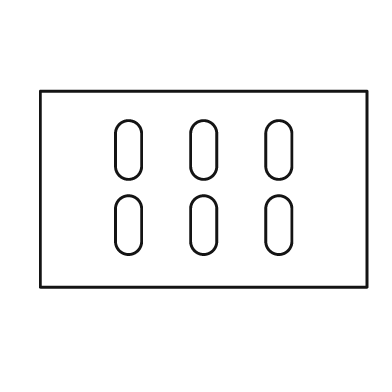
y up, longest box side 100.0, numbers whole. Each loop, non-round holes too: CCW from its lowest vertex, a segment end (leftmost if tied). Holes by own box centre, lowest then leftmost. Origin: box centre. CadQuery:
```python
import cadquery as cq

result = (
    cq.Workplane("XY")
    .moveTo(-50.0, -30.0)
    .lineTo(50.0, -30.0)
    .lineTo(50.0, 30.0)
    .lineTo(-50.0, 30.0)
    .close()
    .moveTo(-27.0, -16.0)
    .threePointArc((-23.0, -20.0), (-19.0, -16.0))
    .lineTo(-19.0, -6.0)
    .threePointArc((-23.0, -2.0), (-27.0, -6.0))
    .close()
    .moveTo(-4.0, -16.0)
    .threePointArc((0.0, -20.0), (4.0, -16.0))
    .lineTo(4.0, -6.0)
    .threePointArc((0.0, -2.0), (-4.0, -6.0))
    .close()
    .moveTo(19.0, -16.0)
    .threePointArc((23.0, -20.0), (27.0, -16.0))
    .lineTo(27.0, -6.0)
    .threePointArc((23.0, -2.0), (19.0, -6.0))
    .close()
    .moveTo(-27.0, 7.0)
    .threePointArc((-23.0, 3.0), (-19.0, 7.0))
    .lineTo(-19.0, 17.0)
    .threePointArc((-23.0, 21.0), (-27.0, 17.0))
    .close()
    .moveTo(-4.0, 7.0)
    .threePointArc((0.0, 3.0), (4.0, 7.0))
    .lineTo(4.0, 17.0)
    .threePointArc((0.0, 21.0), (-4.0, 17.0))
    .close()
    .moveTo(19.0, 7.0)
    .threePointArc((23.0, 3.0), (27.0, 7.0))
    .lineTo(27.0, 17.0)
    .threePointArc((23.0, 21.0), (19.0, 17.0))
    .close()
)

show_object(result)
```